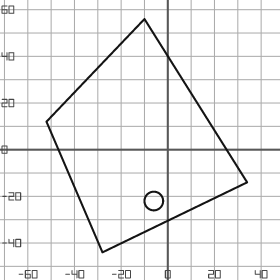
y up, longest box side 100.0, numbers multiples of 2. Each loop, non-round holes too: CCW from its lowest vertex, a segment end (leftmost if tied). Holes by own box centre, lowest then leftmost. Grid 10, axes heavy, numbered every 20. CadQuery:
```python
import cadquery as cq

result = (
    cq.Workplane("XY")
    .moveTo(-28.0, -44.0)
    .lineTo(34.0, -14.0)
    .lineTo(-10.0, 56.0)
    .lineTo(-52.0, 12.0)
    .close()
    .moveTo(-6.0, -22.0)
    .circle(4.0)
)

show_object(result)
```